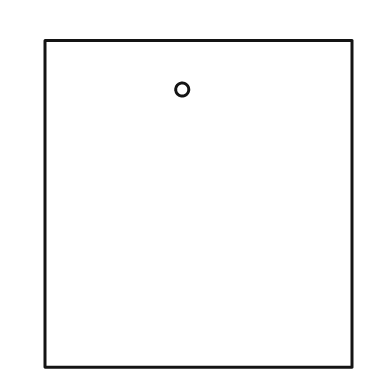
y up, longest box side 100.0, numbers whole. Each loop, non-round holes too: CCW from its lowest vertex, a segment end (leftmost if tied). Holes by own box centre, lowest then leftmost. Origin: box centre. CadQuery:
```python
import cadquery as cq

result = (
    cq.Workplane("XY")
    .moveTo(-47.0, -50.0)
    .lineTo(47.0, -50.0)
    .lineTo(47.0, 50.0)
    .lineTo(-47.0, 50.0)
    .close()
    .moveTo(-5.0, 35.0)
    .circle(2.0)
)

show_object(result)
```